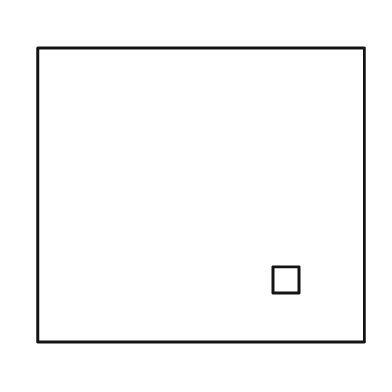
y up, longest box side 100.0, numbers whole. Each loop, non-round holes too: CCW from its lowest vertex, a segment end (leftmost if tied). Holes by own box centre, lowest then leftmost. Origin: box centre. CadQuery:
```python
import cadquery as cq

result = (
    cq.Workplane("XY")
    .moveTo(-50.0, -45.0)
    .lineTo(50.0, -45.0)
    .lineTo(50.0, 45.0)
    .lineTo(-50.0, 45.0)
    .close()
    .moveTo(22.0, -30.0)
    .lineTo(30.0, -30.0)
    .lineTo(30.0, -22.0)
    .lineTo(22.0, -22.0)
    .close()
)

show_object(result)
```